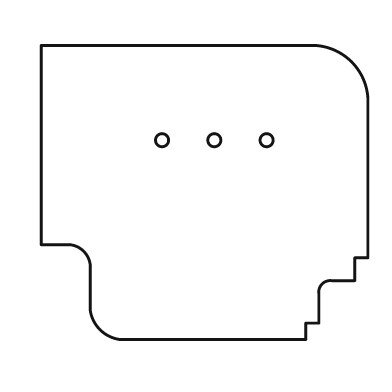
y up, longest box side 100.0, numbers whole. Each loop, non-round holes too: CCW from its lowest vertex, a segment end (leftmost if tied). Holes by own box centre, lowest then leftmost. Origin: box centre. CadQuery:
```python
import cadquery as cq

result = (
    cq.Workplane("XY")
    .moveTo(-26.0, -45.0)
    .lineTo(31.0, -45.0)
    .lineTo(31.0, -40.0)
    .lineTo(35.0, -40.0)
    .lineTo(35.0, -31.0)
    .threePointArc((36.0, -28.0), (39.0, -27.0))
    .lineTo(46.0, -27.0)
    .lineTo(46.0, -20.0)
    .lineTo(50.0, -20.0)
    .lineTo(50.0, 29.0)
    .threePointArc((45.0, 40.0), (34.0, 45.0))
    .lineTo(-50.0, 45.0)
    .lineTo(-50.0, -16.0)
    .lineTo(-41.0, -16.0)
    .threePointArc((-37.0, -18.0), (-35.0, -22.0))
    .lineTo(-35.0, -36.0)
    .threePointArc((-32.0, -42.0), (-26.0, -45.0))
    .close()
    .moveTo(-13.0, 16.0)
    .circle(2.0)
    .moveTo(3.0, 16.0)
    .circle(2.0)
    .moveTo(19.0, 16.0)
    .circle(2.0)
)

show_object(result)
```